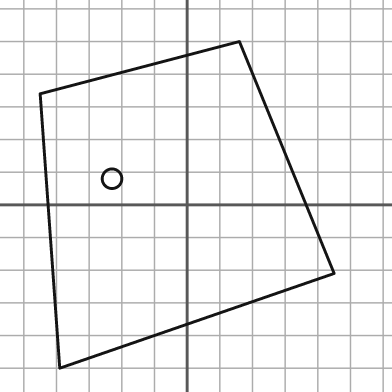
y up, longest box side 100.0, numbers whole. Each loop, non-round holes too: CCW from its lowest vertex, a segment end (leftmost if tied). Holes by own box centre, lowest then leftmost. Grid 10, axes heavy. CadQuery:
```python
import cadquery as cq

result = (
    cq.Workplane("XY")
    .moveTo(-39.0, -50.0)
    .lineTo(45.0, -21.0)
    .lineTo(16.0, 50.0)
    .lineTo(-45.0, 34.0)
    .close()
    .moveTo(-23.0, 8.0)
    .circle(3.0)
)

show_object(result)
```